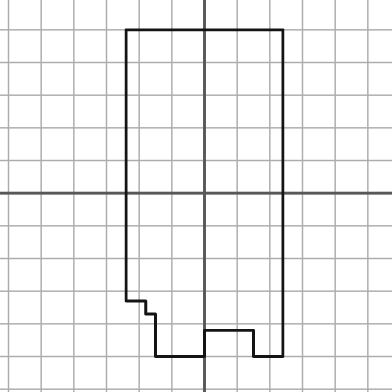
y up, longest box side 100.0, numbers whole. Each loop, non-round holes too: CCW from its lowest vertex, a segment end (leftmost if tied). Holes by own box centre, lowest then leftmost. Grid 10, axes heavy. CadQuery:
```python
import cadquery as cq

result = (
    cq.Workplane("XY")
    .moveTo(-15.0, -50.0)
    .lineTo(0.0, -50.0)
    .lineTo(0.0, -42.0)
    .lineTo(15.0, -42.0)
    .lineTo(15.0, -50.0)
    .lineTo(24.0, -50.0)
    .lineTo(24.0, 50.0)
    .lineTo(-24.0, 50.0)
    .lineTo(-24.0, -33.0)
    .lineTo(-18.0, -33.0)
    .lineTo(-18.0, -37.0)
    .lineTo(-15.0, -37.0)
    .close()
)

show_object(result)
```